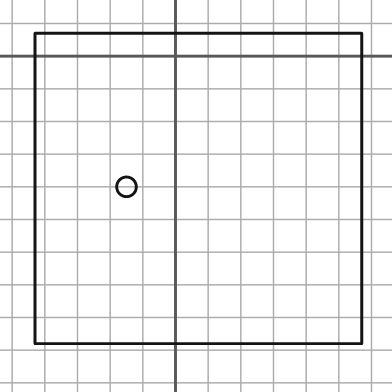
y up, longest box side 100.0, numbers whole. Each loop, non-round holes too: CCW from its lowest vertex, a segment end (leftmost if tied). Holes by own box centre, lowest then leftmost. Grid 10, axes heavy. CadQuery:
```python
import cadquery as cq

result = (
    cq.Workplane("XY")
    .moveTo(-43.0, -88.0)
    .lineTo(57.0, -88.0)
    .lineTo(57.0, 7.0)
    .lineTo(-43.0, 7.0)
    .close()
    .moveTo(-15.0, -40.0)
    .circle(3.0)
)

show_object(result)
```